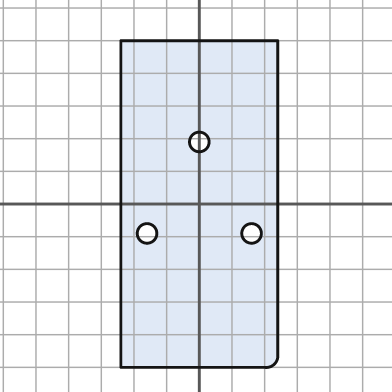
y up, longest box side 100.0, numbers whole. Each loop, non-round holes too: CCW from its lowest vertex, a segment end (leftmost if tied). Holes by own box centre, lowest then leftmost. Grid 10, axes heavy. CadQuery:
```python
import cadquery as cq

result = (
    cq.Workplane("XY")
    .moveTo(-24.0, -50.0)
    .lineTo(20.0, -50.0)
    .threePointArc((23.0, -49.0), (24.0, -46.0))
    .lineTo(24.0, 50.0)
    .lineTo(-24.0, 50.0)
    .close()
    .moveTo(-16.0, -9.0)
    .circle(3.0)
    .moveTo(16.0, -9.0)
    .circle(3.0)
    .moveTo(0.0, 19.0)
    .circle(3.0)
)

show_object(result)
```